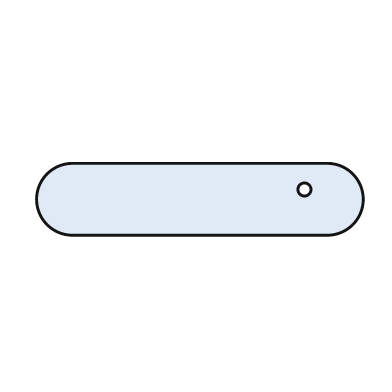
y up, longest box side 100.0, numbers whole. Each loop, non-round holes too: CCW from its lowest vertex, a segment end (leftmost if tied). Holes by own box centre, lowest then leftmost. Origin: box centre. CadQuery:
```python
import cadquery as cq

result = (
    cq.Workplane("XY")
    .moveTo(-39.0, -11.0)
    .lineTo(39.0, -11.0)
    .threePointArc((50.0, 0.0), (39.0, 11.0))
    .lineTo(-39.0, 11.0)
    .threePointArc((-50.0, 0.0), (-39.0, -11.0))
    .close()
    .moveTo(32.0, 3.0)
    .circle(2.0)
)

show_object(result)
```